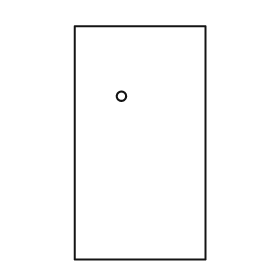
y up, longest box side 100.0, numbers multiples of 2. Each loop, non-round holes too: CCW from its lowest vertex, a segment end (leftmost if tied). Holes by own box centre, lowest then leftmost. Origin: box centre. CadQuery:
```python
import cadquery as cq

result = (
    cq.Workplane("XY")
    .moveTo(-28.0, -50.0)
    .lineTo(28.0, -50.0)
    .lineTo(28.0, 50.0)
    .lineTo(-28.0, 50.0)
    .close()
    .moveTo(-8.0, 20.0)
    .circle(2.0)
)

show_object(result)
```